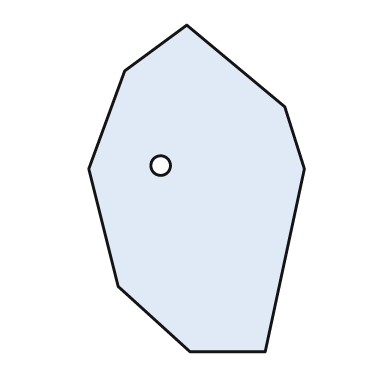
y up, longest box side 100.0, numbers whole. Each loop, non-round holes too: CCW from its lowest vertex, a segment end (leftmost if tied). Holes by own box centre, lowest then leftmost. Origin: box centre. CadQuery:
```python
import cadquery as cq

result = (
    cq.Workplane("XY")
    .moveTo(-2.0, -50.0)
    .lineTo(21.0, -50.0)
    .lineTo(33.0, 6.0)
    .lineTo(27.0, 25.0)
    .lineTo(-3.0, 50.0)
    .lineTo(-22.0, 36.0)
    .lineTo(-33.0, 6.0)
    .lineTo(-24.0, -30.0)
    .close()
    .moveTo(-11.0, 7.0)
    .circle(3.0)
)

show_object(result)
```